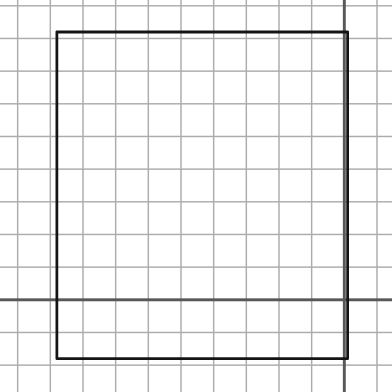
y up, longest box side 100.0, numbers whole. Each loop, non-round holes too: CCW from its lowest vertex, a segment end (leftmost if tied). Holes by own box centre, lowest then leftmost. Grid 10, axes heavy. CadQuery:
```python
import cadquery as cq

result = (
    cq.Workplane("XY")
    .moveTo(-88.0, -18.0)
    .lineTo(1.0, -18.0)
    .lineTo(1.0, 82.0)
    .lineTo(-88.0, 82.0)
    .close()
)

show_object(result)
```